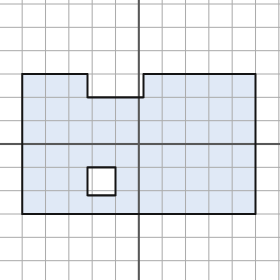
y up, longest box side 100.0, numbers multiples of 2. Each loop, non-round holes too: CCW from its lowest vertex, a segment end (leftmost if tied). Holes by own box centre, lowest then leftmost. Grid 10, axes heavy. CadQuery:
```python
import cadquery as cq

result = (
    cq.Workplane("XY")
    .moveTo(-50.0, -30.0)
    .lineTo(50.0, -30.0)
    .lineTo(50.0, 30.0)
    .lineTo(2.0, 30.0)
    .lineTo(2.0, 20.0)
    .lineTo(-22.0, 20.0)
    .lineTo(-22.0, 30.0)
    .lineTo(-50.0, 30.0)
    .close()
    .moveTo(-22.0, -22.0)
    .lineTo(-10.0, -22.0)
    .lineTo(-10.0, -10.0)
    .lineTo(-22.0, -10.0)
    .close()
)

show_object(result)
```